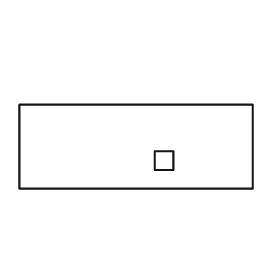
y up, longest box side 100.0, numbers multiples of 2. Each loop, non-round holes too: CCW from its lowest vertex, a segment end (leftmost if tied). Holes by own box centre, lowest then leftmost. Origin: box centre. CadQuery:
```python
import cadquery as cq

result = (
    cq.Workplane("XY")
    .moveTo(-50.0, -18.0)
    .lineTo(50.0, -18.0)
    .lineTo(50.0, 18.0)
    .lineTo(-50.0, 18.0)
    .close()
    .moveTo(8.0, -10.0)
    .lineTo(16.0, -10.0)
    .lineTo(16.0, -2.0)
    .lineTo(8.0, -2.0)
    .close()
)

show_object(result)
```